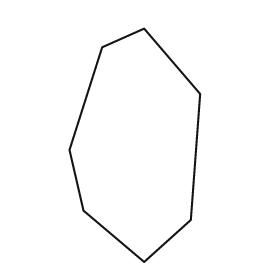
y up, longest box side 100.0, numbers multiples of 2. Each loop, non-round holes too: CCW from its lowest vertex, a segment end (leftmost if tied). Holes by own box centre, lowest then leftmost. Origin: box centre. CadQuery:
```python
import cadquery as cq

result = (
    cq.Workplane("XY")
    .moveTo(4.0, -50.0)
    .lineTo(24.0, -32.0)
    .lineTo(28.0, 22.0)
    .lineTo(4.0, 50.0)
    .lineTo(-14.0, 42.0)
    .lineTo(-28.0, -2.0)
    .lineTo(-22.0, -28.0)
    .close()
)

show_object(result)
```